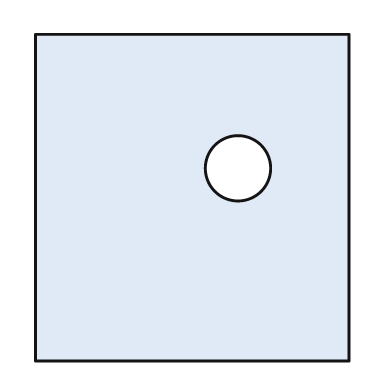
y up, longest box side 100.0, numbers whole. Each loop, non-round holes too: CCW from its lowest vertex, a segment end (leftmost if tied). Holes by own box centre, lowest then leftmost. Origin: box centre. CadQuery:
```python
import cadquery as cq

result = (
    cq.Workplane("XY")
    .moveTo(-48.0, -50.0)
    .lineTo(48.0, -50.0)
    .lineTo(48.0, 50.0)
    .lineTo(-48.0, 50.0)
    .close()
    .moveTo(14.0, 9.0)
    .circle(10.0)
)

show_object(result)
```